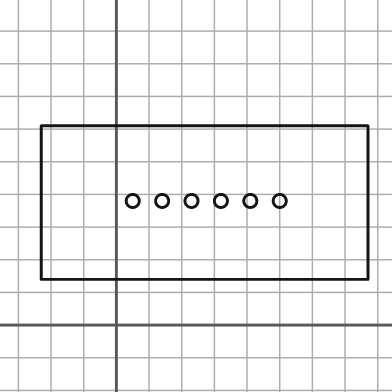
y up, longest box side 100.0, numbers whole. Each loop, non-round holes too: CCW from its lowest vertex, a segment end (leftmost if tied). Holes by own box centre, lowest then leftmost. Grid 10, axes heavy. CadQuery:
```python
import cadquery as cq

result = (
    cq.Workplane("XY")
    .moveTo(-23.0, 14.0)
    .lineTo(77.0, 14.0)
    .lineTo(77.0, 61.0)
    .lineTo(-23.0, 61.0)
    .close()
    .moveTo(5.0, 38.0)
    .circle(2.0)
    .moveTo(14.0, 38.0)
    .circle(2.0)
    .moveTo(23.0, 38.0)
    .circle(2.0)
    .moveTo(32.0, 38.0)
    .circle(2.0)
    .moveTo(41.0, 38.0)
    .circle(2.0)
    .moveTo(50.0, 38.0)
    .circle(2.0)
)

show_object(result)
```